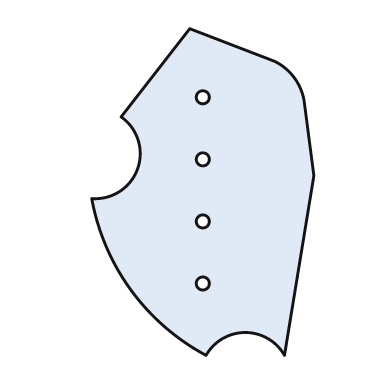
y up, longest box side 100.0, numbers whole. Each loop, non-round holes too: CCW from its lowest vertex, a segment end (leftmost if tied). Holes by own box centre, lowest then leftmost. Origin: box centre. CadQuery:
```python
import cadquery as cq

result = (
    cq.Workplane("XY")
    .moveTo(1.0, -50.0)
    .threePointArc((13.0, -43.0), (25.0, -50.0))
    .lineTo(34.0, 5.0)
    .lineTo(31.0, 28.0)
    .threePointArc((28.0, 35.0), (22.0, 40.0))
    .lineTo(-4.0, 50.0)
    .lineTo(-25.0, 23.0)
    .threePointArc((-20.0, 7.0), (-34.0, -2.0))
    .threePointArc((-22.0, -30.0), (1.0, -50.0))
    .close()
    .moveTo(0.0, -28.0)
    .circle(2.0)
    .moveTo(0.0, -9.0)
    .circle(2.0)
    .moveTo(0.0, 10.0)
    .circle(2.0)
    .moveTo(0.0, 29.0)
    .circle(2.0)
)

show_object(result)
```